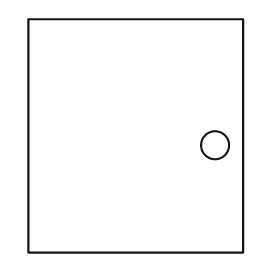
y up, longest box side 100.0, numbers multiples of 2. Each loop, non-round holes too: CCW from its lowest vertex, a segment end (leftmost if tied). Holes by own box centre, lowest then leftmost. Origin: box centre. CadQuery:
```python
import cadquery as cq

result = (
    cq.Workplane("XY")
    .moveTo(-46.0, -50.0)
    .lineTo(46.0, -50.0)
    .lineTo(46.0, 50.0)
    .lineTo(-46.0, 50.0)
    .close()
    .moveTo(34.0, -4.0)
    .circle(6.0)
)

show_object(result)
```